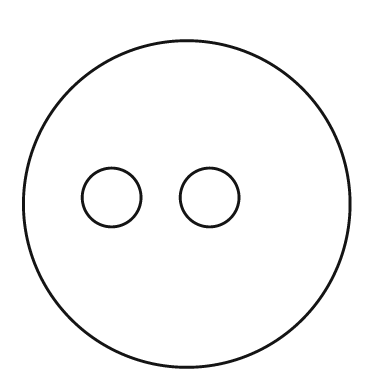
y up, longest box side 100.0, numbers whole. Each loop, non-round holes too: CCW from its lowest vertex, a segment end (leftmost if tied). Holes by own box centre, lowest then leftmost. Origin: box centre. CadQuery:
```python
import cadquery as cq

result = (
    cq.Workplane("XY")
    .moveTo(0.0, 0.0)
    .circle(50.0)
    .moveTo(-23.0, 2.0)
    .circle(9.0)
    .moveTo(7.0, 2.0)
    .circle(9.0)
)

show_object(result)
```